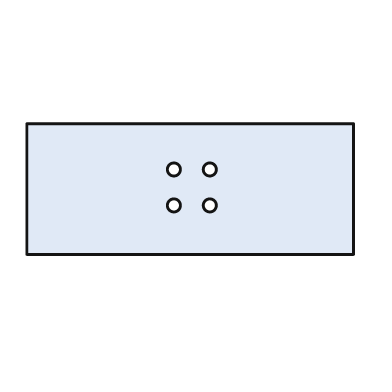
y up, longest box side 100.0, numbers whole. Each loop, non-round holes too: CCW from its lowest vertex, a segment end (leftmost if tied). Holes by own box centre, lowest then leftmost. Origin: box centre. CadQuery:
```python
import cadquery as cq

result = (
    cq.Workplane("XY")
    .moveTo(-50.0, -20.0)
    .lineTo(50.0, -20.0)
    .lineTo(50.0, 20.0)
    .lineTo(-50.0, 20.0)
    .close()
    .moveTo(-5.0, -5.0)
    .circle(2.0)
    .moveTo(6.0, -5.0)
    .circle(2.0)
    .moveTo(-5.0, 6.0)
    .circle(2.0)
    .moveTo(6.0, 6.0)
    .circle(2.0)
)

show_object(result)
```